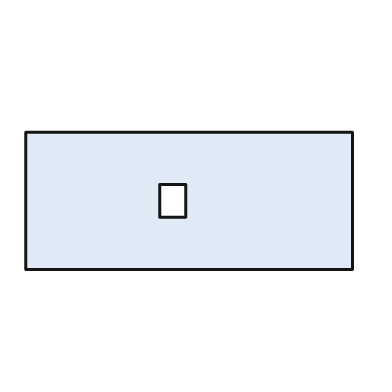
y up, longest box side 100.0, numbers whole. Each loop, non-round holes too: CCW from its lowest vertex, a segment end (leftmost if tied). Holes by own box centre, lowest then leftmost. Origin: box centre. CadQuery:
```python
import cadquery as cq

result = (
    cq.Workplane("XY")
    .moveTo(-50.0, -21.0)
    .lineTo(50.0, -21.0)
    .lineTo(50.0, 21.0)
    .lineTo(-50.0, 21.0)
    .close()
    .moveTo(-9.0, -5.0)
    .lineTo(-1.0, -5.0)
    .lineTo(-1.0, 5.0)
    .lineTo(-9.0, 5.0)
    .close()
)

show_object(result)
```